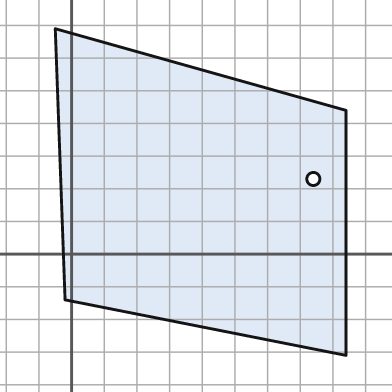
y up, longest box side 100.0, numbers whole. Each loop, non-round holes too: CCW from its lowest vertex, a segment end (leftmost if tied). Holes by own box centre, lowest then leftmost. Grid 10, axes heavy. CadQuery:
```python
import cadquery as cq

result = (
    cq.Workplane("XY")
    .moveTo(84.0, -31.0)
    .lineTo(84.0, 44.0)
    .lineTo(-5.0, 69.0)
    .lineTo(-2.0, -14.0)
    .close()
    .moveTo(74.0, 23.0)
    .circle(2.0)
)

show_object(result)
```